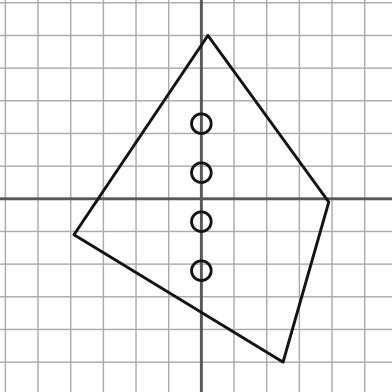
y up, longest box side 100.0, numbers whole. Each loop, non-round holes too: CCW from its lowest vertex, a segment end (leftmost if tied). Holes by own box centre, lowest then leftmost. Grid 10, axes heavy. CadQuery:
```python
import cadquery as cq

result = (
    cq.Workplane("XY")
    .moveTo(25.0, -50.0)
    .lineTo(39.0, -1.0)
    .lineTo(2.0, 50.0)
    .lineTo(-39.0, -11.0)
    .close()
    .moveTo(0.0, -22.0)
    .circle(3.0)
    .moveTo(0.0, -7.0)
    .circle(3.0)
    .moveTo(0.0, 8.0)
    .circle(3.0)
    .moveTo(0.0, 23.0)
    .circle(3.0)
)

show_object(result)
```